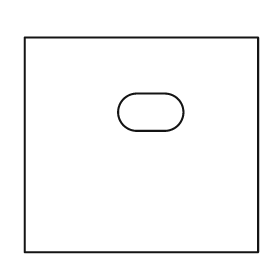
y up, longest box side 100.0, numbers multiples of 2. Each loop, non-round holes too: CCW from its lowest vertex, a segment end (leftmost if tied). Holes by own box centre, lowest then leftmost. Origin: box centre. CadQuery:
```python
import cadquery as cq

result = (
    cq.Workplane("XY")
    .moveTo(-50.0, -46.0)
    .lineTo(50.0, -46.0)
    .lineTo(50.0, 46.0)
    .lineTo(-50.0, 46.0)
    .close()
    .moveTo(-2.0, 6.0)
    .lineTo(10.0, 6.0)
    .threePointArc((18.0, 14.0), (10.0, 22.0))
    .lineTo(-2.0, 22.0)
    .threePointArc((-10.0, 14.0), (-2.0, 6.0))
    .close()
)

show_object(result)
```